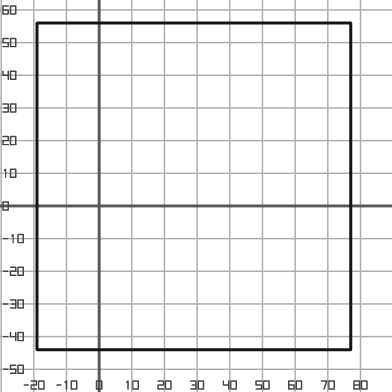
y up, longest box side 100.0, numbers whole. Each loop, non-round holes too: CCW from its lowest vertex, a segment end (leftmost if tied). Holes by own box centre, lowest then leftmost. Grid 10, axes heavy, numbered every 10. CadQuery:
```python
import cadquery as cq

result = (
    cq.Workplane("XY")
    .moveTo(-19.0, -44.0)
    .lineTo(77.0, -44.0)
    .lineTo(77.0, 56.0)
    .lineTo(-19.0, 56.0)
    .close()
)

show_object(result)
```